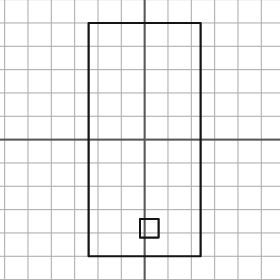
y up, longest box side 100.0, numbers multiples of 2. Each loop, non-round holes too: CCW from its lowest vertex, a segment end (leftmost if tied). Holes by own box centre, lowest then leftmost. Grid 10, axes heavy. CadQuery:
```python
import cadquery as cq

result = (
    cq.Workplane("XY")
    .moveTo(-24.0, -50.0)
    .lineTo(24.0, -50.0)
    .lineTo(24.0, 50.0)
    .lineTo(-24.0, 50.0)
    .close()
    .moveTo(-2.0, -42.0)
    .lineTo(6.0, -42.0)
    .lineTo(6.0, -34.0)
    .lineTo(-2.0, -34.0)
    .close()
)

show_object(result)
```